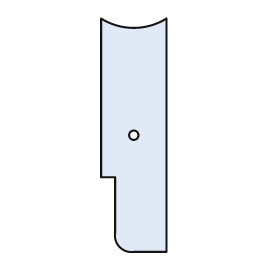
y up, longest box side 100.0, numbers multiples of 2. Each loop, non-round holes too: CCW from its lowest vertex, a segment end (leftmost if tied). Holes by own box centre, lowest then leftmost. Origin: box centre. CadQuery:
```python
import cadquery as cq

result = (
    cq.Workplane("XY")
    .moveTo(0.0, -50.0)
    .lineTo(14.0, -50.0)
    .lineTo(14.0, 50.0)
    .threePointArc((0.0, 46.0), (-14.0, 50.0))
    .lineTo(-14.0, -18.0)
    .lineTo(-8.0, -18.0)
    .lineTo(-8.0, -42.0)
    .threePointArc((-6.0, -48.0), (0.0, -50.0))
    .close()
    .moveTo(0.0, 0.0)
    .circle(2.0)
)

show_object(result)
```